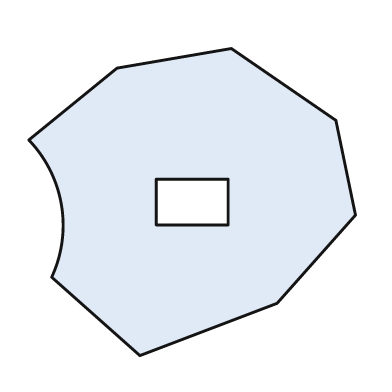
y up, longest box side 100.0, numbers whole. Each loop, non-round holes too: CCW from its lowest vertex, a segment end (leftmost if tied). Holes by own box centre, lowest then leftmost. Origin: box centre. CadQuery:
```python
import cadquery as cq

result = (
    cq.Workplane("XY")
    .moveTo(-16.0, -47.0)
    .lineTo(26.0, -31.0)
    .lineTo(50.0, -4.0)
    .lineTo(44.0, 25.0)
    .lineTo(12.0, 47.0)
    .lineTo(-23.0, 41.0)
    .lineTo(-50.0, 19.0)
    .threePointArc((-40.0, -1.0), (-43.0, -23.0))
    .close()
    .moveTo(-11.0, -7.0)
    .lineTo(11.0, -7.0)
    .lineTo(11.0, 7.0)
    .lineTo(-11.0, 7.0)
    .close()
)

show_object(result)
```